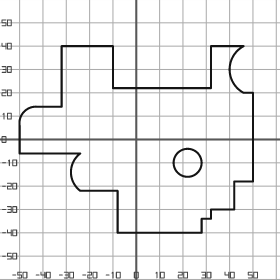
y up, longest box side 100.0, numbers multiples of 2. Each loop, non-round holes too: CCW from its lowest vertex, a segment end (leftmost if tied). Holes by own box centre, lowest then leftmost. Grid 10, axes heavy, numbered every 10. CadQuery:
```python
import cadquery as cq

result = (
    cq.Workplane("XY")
    .moveTo(-8.0, -40.0)
    .lineTo(28.0, -40.0)
    .lineTo(28.0, -34.0)
    .lineTo(32.0, -34.0)
    .lineTo(32.0, -30.0)
    .lineTo(42.0, -30.0)
    .lineTo(42.0, -18.0)
    .lineTo(50.0, -18.0)
    .lineTo(50.0, 20.0)
    .lineTo(46.0, 20.0)
    .threePointArc((40.0, 30.0), (46.0, 40.0))
    .lineTo(32.0, 40.0)
    .lineTo(32.0, 22.0)
    .lineTo(-10.0, 22.0)
    .lineTo(-10.0, 40.0)
    .lineTo(-32.0, 40.0)
    .lineTo(-32.0, 14.0)
    .lineTo(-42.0, 14.0)
    .threePointArc((-48.0, 12.0), (-50.0, 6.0))
    .lineTo(-50.0, -6.0)
    .lineTo(-24.0, -6.0)
    .threePointArc((-28.0, -14.0), (-24.0, -22.0))
    .lineTo(-8.0, -22.0)
    .close()
    .moveTo(22.0, -10.0)
    .circle(6.0)
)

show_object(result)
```